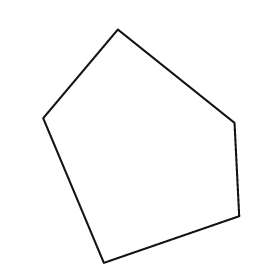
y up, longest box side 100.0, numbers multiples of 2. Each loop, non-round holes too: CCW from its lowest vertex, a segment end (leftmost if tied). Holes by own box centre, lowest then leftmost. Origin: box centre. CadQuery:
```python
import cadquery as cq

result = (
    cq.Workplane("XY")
    .moveTo(-16.0, -50.0)
    .lineTo(42.0, -30.0)
    .lineTo(40.0, 10.0)
    .lineTo(-10.0, 50.0)
    .lineTo(-42.0, 12.0)
    .close()
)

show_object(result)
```